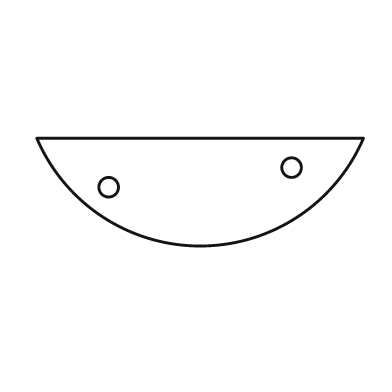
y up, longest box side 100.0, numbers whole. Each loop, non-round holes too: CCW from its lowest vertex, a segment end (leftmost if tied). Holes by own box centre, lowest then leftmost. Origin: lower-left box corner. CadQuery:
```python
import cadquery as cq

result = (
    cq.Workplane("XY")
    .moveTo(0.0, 33.0)
    .threePointArc((50.0, 0.0), (100.0, 33.0))
    .close()
    .moveTo(22.0, 18.0)
    .circle(3.0)
    .moveTo(78.0, 24.0)
    .circle(3.0)
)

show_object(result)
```